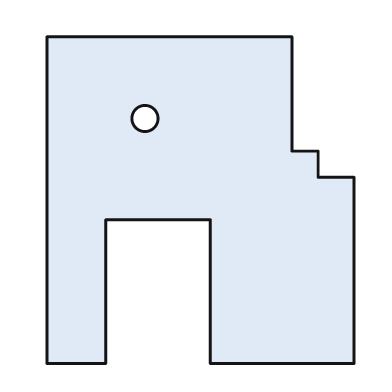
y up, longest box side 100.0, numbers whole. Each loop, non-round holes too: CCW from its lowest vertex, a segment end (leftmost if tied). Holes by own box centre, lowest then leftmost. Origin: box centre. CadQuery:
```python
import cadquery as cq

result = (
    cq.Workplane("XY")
    .moveTo(-47.0, -50.0)
    .lineTo(-29.0, -50.0)
    .lineTo(-29.0, -6.0)
    .lineTo(3.0, -6.0)
    .lineTo(3.0, -50.0)
    .lineTo(47.0, -50.0)
    .lineTo(47.0, 7.0)
    .lineTo(36.0, 7.0)
    .lineTo(36.0, 15.0)
    .lineTo(28.0, 15.0)
    .lineTo(28.0, 50.0)
    .lineTo(-47.0, 50.0)
    .close()
    .moveTo(-17.0, 25.0)
    .circle(4.0)
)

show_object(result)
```